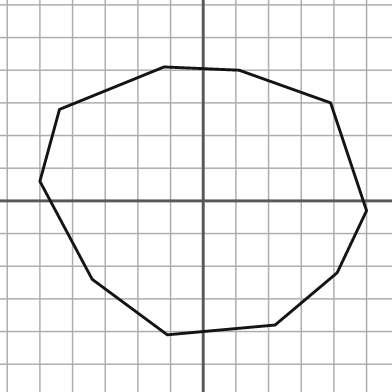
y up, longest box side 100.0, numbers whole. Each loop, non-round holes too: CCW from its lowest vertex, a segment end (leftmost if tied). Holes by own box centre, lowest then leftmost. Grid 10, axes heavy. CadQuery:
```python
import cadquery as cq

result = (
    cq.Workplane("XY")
    .moveTo(-11.0, -41.0)
    .lineTo(22.0, -38.0)
    .lineTo(41.0, -22.0)
    .lineTo(50.0, -3.0)
    .lineTo(39.0, 30.0)
    .lineTo(11.0, 40.0)
    .lineTo(-12.0, 41.0)
    .lineTo(-44.0, 28.0)
    .lineTo(-50.0, 6.0)
    .lineTo(-34.0, -24.0)
    .close()
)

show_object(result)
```